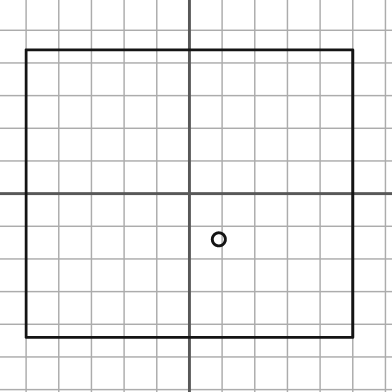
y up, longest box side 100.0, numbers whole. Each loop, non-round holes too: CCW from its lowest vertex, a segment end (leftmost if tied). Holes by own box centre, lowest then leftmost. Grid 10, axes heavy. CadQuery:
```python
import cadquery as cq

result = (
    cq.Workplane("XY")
    .moveTo(-50.0, -44.0)
    .lineTo(50.0, -44.0)
    .lineTo(50.0, 44.0)
    .lineTo(-50.0, 44.0)
    .close()
    .moveTo(9.0, -14.0)
    .circle(2.0)
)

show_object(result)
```